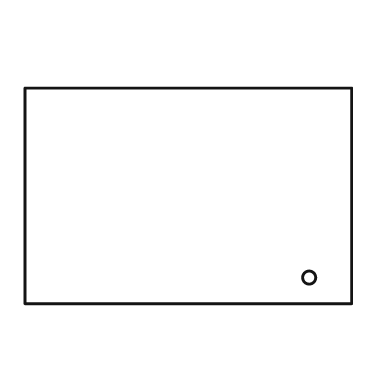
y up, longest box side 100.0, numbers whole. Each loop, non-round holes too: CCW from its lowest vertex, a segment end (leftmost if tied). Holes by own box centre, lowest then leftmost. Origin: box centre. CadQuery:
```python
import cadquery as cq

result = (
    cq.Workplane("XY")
    .moveTo(-50.0, -33.0)
    .lineTo(50.0, -33.0)
    .lineTo(50.0, 33.0)
    .lineTo(-50.0, 33.0)
    .close()
    .moveTo(37.0, -25.0)
    .circle(2.0)
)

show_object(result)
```